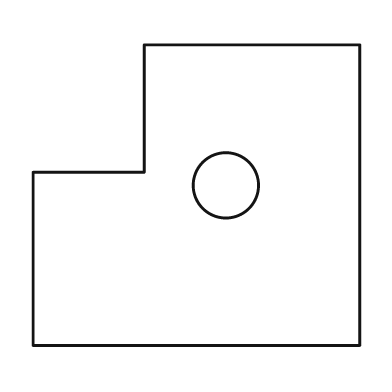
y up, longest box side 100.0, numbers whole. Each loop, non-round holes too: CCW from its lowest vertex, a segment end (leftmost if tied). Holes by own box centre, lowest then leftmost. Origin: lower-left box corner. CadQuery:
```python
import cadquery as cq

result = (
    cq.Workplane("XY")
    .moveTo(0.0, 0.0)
    .lineTo(100.0, 0.0)
    .lineTo(100.0, 92.0)
    .lineTo(34.0, 92.0)
    .lineTo(34.0, 53.0)
    .lineTo(0.0, 53.0)
    .close()
    .moveTo(59.0, 49.0)
    .circle(10.0)
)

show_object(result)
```